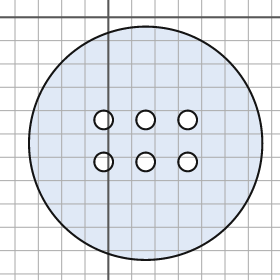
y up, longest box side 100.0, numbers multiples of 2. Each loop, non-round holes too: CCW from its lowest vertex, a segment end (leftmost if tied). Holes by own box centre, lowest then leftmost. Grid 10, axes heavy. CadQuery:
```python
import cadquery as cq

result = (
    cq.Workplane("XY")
    .moveTo(16.0, -54.0)
    .circle(50.0)
    .moveTo(-2.0, -62.0)
    .circle(4.0)
    .moveTo(16.0, -62.0)
    .circle(4.0)
    .moveTo(34.0, -62.0)
    .circle(4.0)
    .moveTo(-2.0, -44.0)
    .circle(4.0)
    .moveTo(16.0, -44.0)
    .circle(4.0)
    .moveTo(34.0, -44.0)
    .circle(4.0)
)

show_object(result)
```